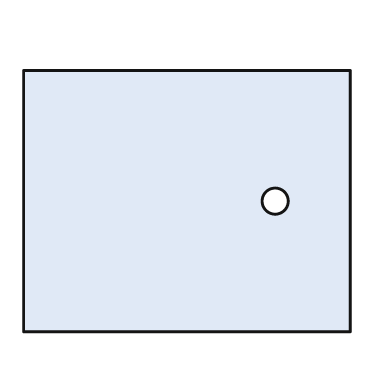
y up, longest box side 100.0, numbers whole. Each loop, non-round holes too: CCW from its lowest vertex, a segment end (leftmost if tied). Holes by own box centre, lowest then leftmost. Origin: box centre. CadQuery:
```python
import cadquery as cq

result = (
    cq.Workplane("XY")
    .moveTo(-50.0, -40.0)
    .lineTo(50.0, -40.0)
    .lineTo(50.0, 40.0)
    .lineTo(-50.0, 40.0)
    .close()
    .moveTo(27.0, 0.0)
    .circle(4.0)
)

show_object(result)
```